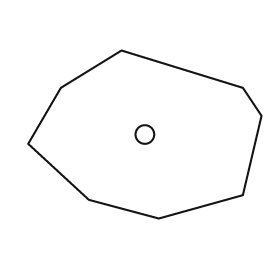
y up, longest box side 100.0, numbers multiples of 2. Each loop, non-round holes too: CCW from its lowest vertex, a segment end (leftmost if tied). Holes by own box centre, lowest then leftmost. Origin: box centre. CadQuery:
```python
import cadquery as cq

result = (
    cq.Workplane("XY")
    .moveTo(6.0, -36.0)
    .lineTo(42.0, -26.0)
    .lineTo(50.0, 8.0)
    .lineTo(42.0, 20.0)
    .lineTo(-10.0, 36.0)
    .lineTo(-36.0, 20.0)
    .lineTo(-50.0, -4.0)
    .lineTo(-24.0, -28.0)
    .close()
    .moveTo(0.0, 0.0)
    .circle(4.0)
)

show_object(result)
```